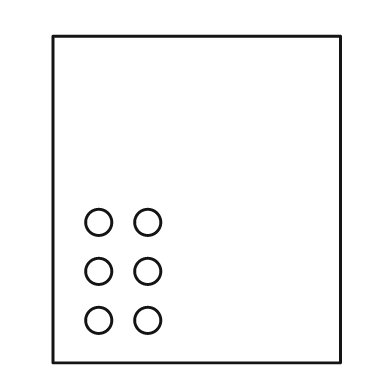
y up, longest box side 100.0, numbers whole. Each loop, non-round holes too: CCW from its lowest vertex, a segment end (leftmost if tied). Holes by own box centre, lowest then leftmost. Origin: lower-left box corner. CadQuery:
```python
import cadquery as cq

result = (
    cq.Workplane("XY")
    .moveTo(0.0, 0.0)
    .lineTo(88.0, 0.0)
    .lineTo(88.0, 100.0)
    .lineTo(0.0, 100.0)
    .close()
    .moveTo(14.0, 13.0)
    .circle(4.0)
    .moveTo(29.0, 13.0)
    .circle(4.0)
    .moveTo(14.0, 28.0)
    .circle(4.0)
    .moveTo(29.0, 28.0)
    .circle(4.0)
    .moveTo(14.0, 43.0)
    .circle(4.0)
    .moveTo(29.0, 43.0)
    .circle(4.0)
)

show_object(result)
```